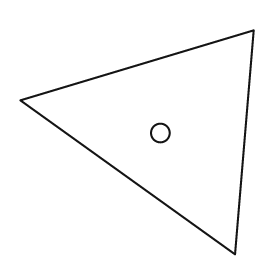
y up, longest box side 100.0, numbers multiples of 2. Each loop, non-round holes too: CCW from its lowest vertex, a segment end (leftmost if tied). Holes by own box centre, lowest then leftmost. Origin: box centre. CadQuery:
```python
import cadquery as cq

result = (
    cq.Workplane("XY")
    .moveTo(42.0, -48.0)
    .lineTo(50.0, 48.0)
    .lineTo(-50.0, 18.0)
    .close()
    .moveTo(10.0, 4.0)
    .circle(4.0)
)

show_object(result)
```